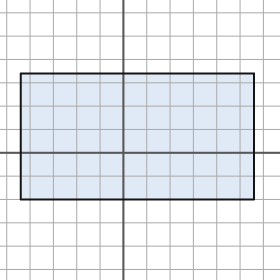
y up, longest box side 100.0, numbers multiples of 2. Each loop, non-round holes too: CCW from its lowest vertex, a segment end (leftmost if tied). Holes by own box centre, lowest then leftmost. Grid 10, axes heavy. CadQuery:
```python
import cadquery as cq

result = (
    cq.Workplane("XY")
    .moveTo(-44.0, -20.0)
    .lineTo(56.0, -20.0)
    .lineTo(56.0, 34.0)
    .lineTo(-44.0, 34.0)
    .close()
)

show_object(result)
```